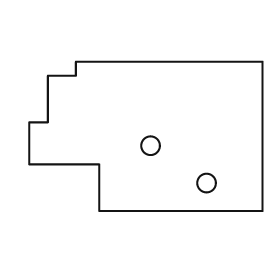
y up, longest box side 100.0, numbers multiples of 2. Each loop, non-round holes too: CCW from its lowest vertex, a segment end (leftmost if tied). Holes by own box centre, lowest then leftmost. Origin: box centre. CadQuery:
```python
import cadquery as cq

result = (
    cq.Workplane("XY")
    .moveTo(-20.0, -32.0)
    .lineTo(50.0, -32.0)
    .lineTo(50.0, 32.0)
    .lineTo(-30.0, 32.0)
    .lineTo(-30.0, 26.0)
    .lineTo(-42.0, 26.0)
    .lineTo(-42.0, 6.0)
    .lineTo(-50.0, 6.0)
    .lineTo(-50.0, -12.0)
    .lineTo(-20.0, -12.0)
    .close()
    .moveTo(26.0, -20.0)
    .circle(4.0)
    .moveTo(2.0, -4.0)
    .circle(4.0)
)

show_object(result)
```